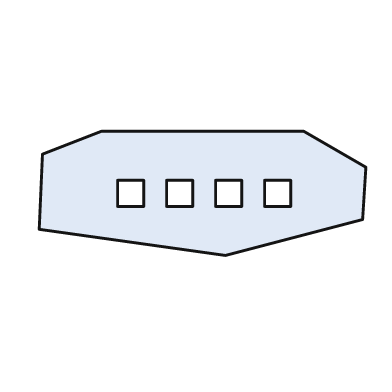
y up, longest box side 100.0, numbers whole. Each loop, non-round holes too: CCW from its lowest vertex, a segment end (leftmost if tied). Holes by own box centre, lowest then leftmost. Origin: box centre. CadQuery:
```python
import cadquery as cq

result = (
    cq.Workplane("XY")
    .moveTo(7.0, -19.0)
    .lineTo(49.0, -8.0)
    .lineTo(50.0, 8.0)
    .lineTo(31.0, 19.0)
    .lineTo(-31.0, 19.0)
    .lineTo(-49.0, 12.0)
    .lineTo(-50.0, -11.0)
    .close()
    .moveTo(-26.0, -4.0)
    .lineTo(-18.0, -4.0)
    .lineTo(-18.0, 4.0)
    .lineTo(-26.0, 4.0)
    .close()
    .moveTo(-11.0, -4.0)
    .lineTo(-3.0, -4.0)
    .lineTo(-3.0, 4.0)
    .lineTo(-11.0, 4.0)
    .close()
    .moveTo(4.0, -4.0)
    .lineTo(12.0, -4.0)
    .lineTo(12.0, 4.0)
    .lineTo(4.0, 4.0)
    .close()
    .moveTo(19.0, -4.0)
    .lineTo(27.0, -4.0)
    .lineTo(27.0, 4.0)
    .lineTo(19.0, 4.0)
    .close()
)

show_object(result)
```